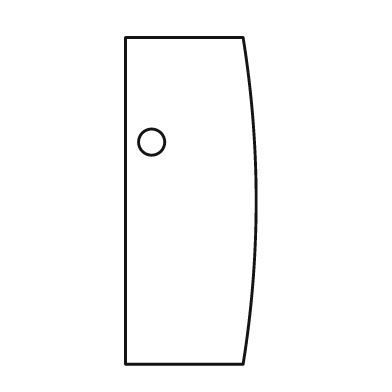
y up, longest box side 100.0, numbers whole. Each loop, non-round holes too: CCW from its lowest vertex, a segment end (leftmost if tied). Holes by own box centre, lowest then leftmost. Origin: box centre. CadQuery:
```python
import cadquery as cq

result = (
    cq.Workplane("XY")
    .moveTo(-20.0, -50.0)
    .lineTo(16.0, -50.0)
    .threePointArc((20.0, 0.0), (16.0, 50.0))
    .lineTo(-20.0, 50.0)
    .close()
    .moveTo(-12.0, 18.0)
    .circle(4.0)
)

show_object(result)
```